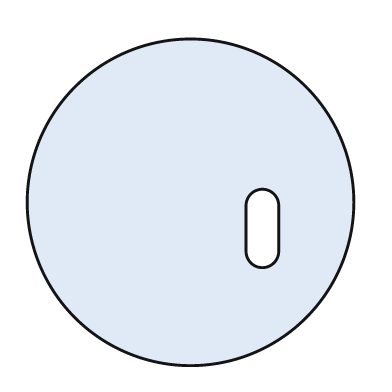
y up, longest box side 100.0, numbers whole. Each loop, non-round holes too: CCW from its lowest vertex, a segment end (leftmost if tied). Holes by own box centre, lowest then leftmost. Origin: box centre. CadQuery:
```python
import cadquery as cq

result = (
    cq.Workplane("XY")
    .moveTo(0.0, 0.0)
    .circle(50.0)
    .moveTo(17.0, -15.0)
    .threePointArc((22.0, -20.0), (27.0, -15.0))
    .lineTo(27.0, -1.0)
    .threePointArc((22.0, 4.0), (17.0, -1.0))
    .close()
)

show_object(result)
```